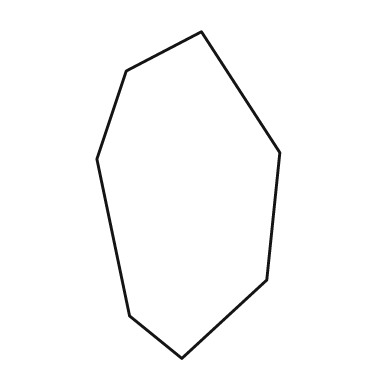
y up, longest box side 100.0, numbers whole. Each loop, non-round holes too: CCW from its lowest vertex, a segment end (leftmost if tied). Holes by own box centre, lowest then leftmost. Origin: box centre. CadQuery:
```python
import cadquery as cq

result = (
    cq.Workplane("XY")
    .moveTo(-2.0, -50.0)
    .lineTo(24.0, -26.0)
    .lineTo(28.0, 13.0)
    .lineTo(4.0, 50.0)
    .lineTo(-19.0, 38.0)
    .lineTo(-28.0, 11.0)
    .lineTo(-18.0, -37.0)
    .close()
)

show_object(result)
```